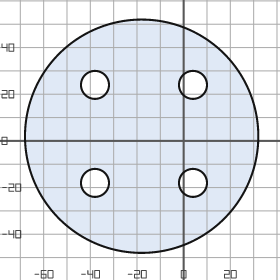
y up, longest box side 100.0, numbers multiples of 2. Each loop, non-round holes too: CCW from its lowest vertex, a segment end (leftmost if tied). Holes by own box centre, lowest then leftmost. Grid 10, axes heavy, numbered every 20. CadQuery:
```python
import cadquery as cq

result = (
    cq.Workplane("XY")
    .moveTo(-18.0, 2.0)
    .circle(50.0)
    .moveTo(-38.0, -18.0)
    .circle(6.0)
    .moveTo(4.0, -18.0)
    .circle(6.0)
    .moveTo(-38.0, 24.0)
    .circle(6.0)
    .moveTo(4.0, 24.0)
    .circle(6.0)
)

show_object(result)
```